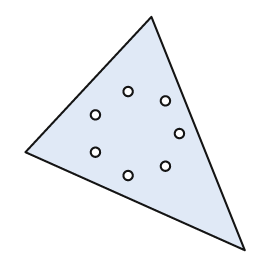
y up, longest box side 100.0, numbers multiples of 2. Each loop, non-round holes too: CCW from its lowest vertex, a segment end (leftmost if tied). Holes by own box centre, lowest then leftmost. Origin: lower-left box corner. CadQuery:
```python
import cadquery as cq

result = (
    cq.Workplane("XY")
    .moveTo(94.0, 0.0)
    .lineTo(54.0, 100.0)
    .lineTo(0.0, 42.0)
    .close()
    .moveTo(44.0, 32.0)
    .circle(2.0)
    .moveTo(60.0, 36.0)
    .circle(2.0)
    .moveTo(30.0, 42.0)
    .circle(2.0)
    .moveTo(66.0, 50.0)
    .circle(2.0)
    .moveTo(30.0, 58.0)
    .circle(2.0)
    .moveTo(60.0, 64.0)
    .circle(2.0)
    .moveTo(44.0, 68.0)
    .circle(2.0)
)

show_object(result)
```